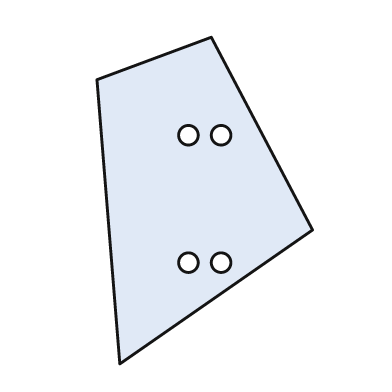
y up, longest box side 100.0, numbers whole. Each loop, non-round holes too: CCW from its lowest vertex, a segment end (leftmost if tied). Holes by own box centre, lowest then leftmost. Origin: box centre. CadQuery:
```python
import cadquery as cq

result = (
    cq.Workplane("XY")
    .moveTo(-26.0, -50.0)
    .lineTo(33.0, -9.0)
    .lineTo(2.0, 50.0)
    .lineTo(-33.0, 37.0)
    .close()
    .moveTo(-5.0, -19.0)
    .circle(3.0)
    .moveTo(5.0, -19.0)
    .circle(3.0)
    .moveTo(-5.0, 20.0)
    .circle(3.0)
    .moveTo(5.0, 20.0)
    .circle(3.0)
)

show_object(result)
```